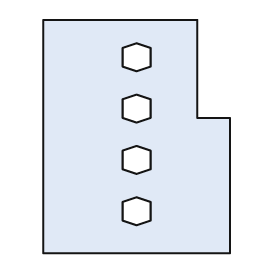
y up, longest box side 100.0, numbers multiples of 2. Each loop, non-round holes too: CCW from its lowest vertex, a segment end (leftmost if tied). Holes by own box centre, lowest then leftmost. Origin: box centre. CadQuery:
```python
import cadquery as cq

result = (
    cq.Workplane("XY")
    .moveTo(-40.0, -50.0)
    .lineTo(40.0, -50.0)
    .lineTo(40.0, 8.0)
    .lineTo(26.0, 8.0)
    .lineTo(26.0, 50.0)
    .lineTo(-40.0, 50.0)
    .close()
    .moveTo(0.0, -38.0)
    .lineTo(6.0, -36.0)
    .lineTo(6.0, -28.0)
    .lineTo(0.0, -26.0)
    .lineTo(-6.0, -28.0)
    .lineTo(-6.0, -36.0)
    .close()
    .moveTo(0.0, -16.0)
    .lineTo(6.0, -14.0)
    .lineTo(6.0, -6.0)
    .lineTo(0.0, -4.0)
    .lineTo(-6.0, -6.0)
    .lineTo(-6.0, -14.0)
    .close()
    .moveTo(0.0, 6.0)
    .lineTo(6.0, 8.0)
    .lineTo(6.0, 16.0)
    .lineTo(0.0, 18.0)
    .lineTo(-6.0, 16.0)
    .lineTo(-6.0, 8.0)
    .close()
    .moveTo(0.0, 28.0)
    .lineTo(6.0, 30.0)
    .lineTo(6.0, 38.0)
    .lineTo(0.0, 40.0)
    .lineTo(-6.0, 38.0)
    .lineTo(-6.0, 30.0)
    .close()
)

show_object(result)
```